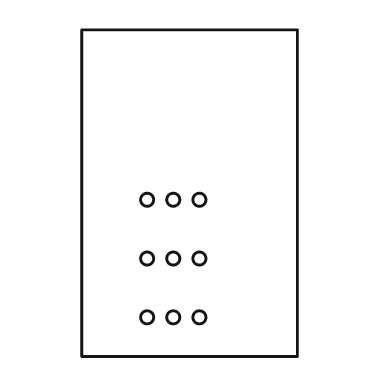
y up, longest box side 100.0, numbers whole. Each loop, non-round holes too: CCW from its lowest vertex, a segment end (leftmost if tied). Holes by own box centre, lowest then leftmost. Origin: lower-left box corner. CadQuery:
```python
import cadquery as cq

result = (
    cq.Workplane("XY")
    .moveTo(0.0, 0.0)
    .lineTo(66.0, 0.0)
    .lineTo(66.0, 100.0)
    .lineTo(0.0, 100.0)
    .close()
    .moveTo(20.0, 12.0)
    .circle(2.0)
    .moveTo(28.0, 12.0)
    .circle(2.0)
    .moveTo(36.0, 12.0)
    .circle(2.0)
    .moveTo(20.0, 30.0)
    .circle(2.0)
    .moveTo(28.0, 30.0)
    .circle(2.0)
    .moveTo(36.0, 30.0)
    .circle(2.0)
    .moveTo(20.0, 48.0)
    .circle(2.0)
    .moveTo(28.0, 48.0)
    .circle(2.0)
    .moveTo(36.0, 48.0)
    .circle(2.0)
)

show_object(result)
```